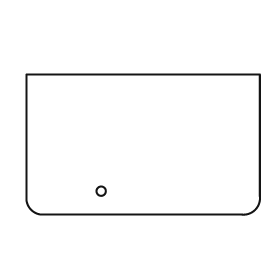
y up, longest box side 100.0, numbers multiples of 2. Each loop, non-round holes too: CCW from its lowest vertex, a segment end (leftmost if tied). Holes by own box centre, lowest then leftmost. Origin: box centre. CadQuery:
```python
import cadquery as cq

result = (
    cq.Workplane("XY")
    .moveTo(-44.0, -30.0)
    .lineTo(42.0, -30.0)
    .threePointArc((48.0, -28.0), (50.0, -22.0))
    .lineTo(50.0, 30.0)
    .lineTo(-50.0, 30.0)
    .lineTo(-50.0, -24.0)
    .threePointArc((-48.0, -28.0), (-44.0, -30.0))
    .close()
    .moveTo(-18.0, -20.0)
    .circle(2.0)
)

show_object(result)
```